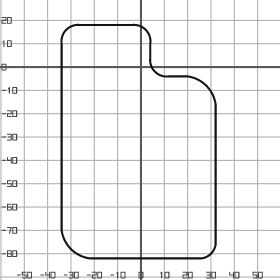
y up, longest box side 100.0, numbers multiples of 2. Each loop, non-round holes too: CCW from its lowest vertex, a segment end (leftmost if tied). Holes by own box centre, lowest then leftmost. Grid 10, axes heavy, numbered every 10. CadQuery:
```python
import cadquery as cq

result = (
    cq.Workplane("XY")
    .moveTo(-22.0, -82.0)
    .lineTo(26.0, -82.0)
    .threePointArc((30.0, -80.0), (32.0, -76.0))
    .lineTo(32.0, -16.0)
    .threePointArc((28.0, -8.0), (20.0, -4.0))
    .lineTo(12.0, -4.0)
    .threePointArc((6.0, -2.0), (4.0, 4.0))
    .lineTo(4.0, 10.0)
    .threePointArc((2.0, 16.0), (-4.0, 18.0))
    .lineTo(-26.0, 18.0)
    .threePointArc((-32.0, 16.0), (-34.0, 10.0))
    .lineTo(-34.0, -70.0)
    .threePointArc((-30.0, -78.0), (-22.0, -82.0))
    .close()
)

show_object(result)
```